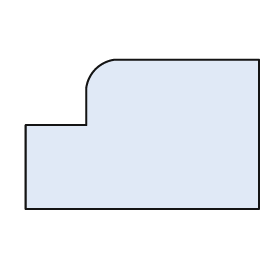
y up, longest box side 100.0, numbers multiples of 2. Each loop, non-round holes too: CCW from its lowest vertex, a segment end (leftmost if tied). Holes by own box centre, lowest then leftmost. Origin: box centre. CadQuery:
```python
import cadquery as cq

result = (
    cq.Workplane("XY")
    .moveTo(-50.0, -32.0)
    .lineTo(50.0, -32.0)
    .lineTo(50.0, 32.0)
    .lineTo(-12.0, 32.0)
    .threePointArc((-20.0, 28.0), (-24.0, 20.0))
    .lineTo(-24.0, 4.0)
    .lineTo(-50.0, 4.0)
    .close()
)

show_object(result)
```